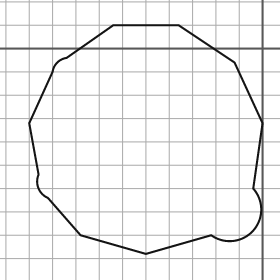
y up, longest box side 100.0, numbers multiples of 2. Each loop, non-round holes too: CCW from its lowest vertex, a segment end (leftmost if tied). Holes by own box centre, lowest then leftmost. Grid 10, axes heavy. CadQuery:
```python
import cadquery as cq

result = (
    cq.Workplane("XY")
    .moveTo(-50.0, -88.0)
    .lineTo(-22.0, -80.0)
    .threePointArc((-4.0, -78.0), (-4.0, -60.0))
    .lineTo(0.0, -32.0)
    .lineTo(-12.0, -6.0)
    .lineTo(-36.0, 10.0)
    .lineTo(-64.0, 10.0)
    .lineTo(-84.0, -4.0)
    .threePointArc((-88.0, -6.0), (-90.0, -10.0))
    .lineTo(-100.0, -32.0)
    .lineTo(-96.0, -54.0)
    .threePointArc((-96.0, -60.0), (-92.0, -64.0))
    .lineTo(-78.0, -80.0)
    .close()
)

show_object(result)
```